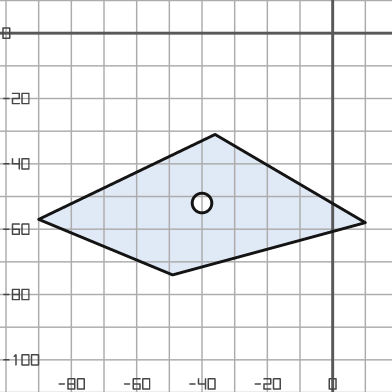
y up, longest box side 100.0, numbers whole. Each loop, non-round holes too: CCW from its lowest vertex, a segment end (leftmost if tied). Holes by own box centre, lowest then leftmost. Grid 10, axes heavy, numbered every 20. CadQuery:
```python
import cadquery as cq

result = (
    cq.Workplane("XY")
    .moveTo(-49.0, -74.0)
    .lineTo(10.0, -58.0)
    .lineTo(-36.0, -31.0)
    .lineTo(-90.0, -57.0)
    .close()
    .moveTo(-40.0, -52.0)
    .circle(3.0)
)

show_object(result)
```